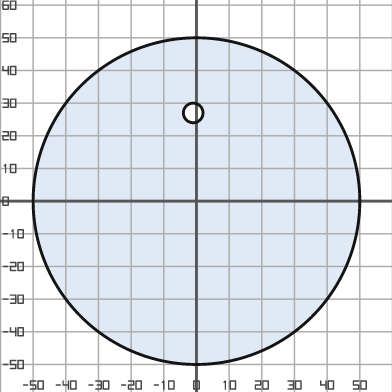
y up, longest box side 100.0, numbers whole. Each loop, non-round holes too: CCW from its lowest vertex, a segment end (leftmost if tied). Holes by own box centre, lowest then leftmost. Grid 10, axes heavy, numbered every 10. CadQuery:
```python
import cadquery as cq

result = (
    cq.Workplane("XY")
    .moveTo(0.0, 0.0)
    .circle(50.0)
    .moveTo(-1.0, 27.0)
    .circle(3.0)
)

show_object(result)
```